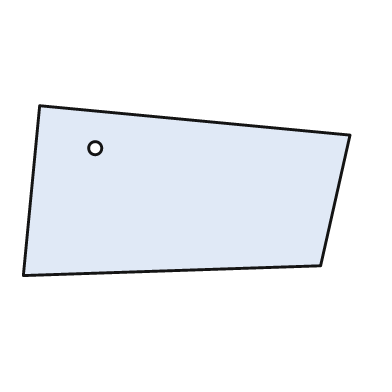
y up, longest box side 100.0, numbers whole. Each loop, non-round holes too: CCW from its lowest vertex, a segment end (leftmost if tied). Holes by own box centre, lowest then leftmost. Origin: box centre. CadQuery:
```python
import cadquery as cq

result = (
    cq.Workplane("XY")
    .moveTo(-50.0, -26.0)
    .lineTo(41.0, -23.0)
    .lineTo(50.0, 17.0)
    .lineTo(-45.0, 26.0)
    .close()
    .moveTo(-28.0, 13.0)
    .circle(2.0)
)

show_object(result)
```